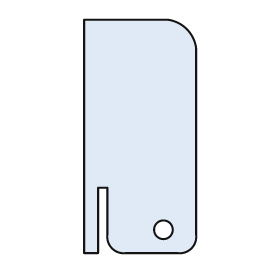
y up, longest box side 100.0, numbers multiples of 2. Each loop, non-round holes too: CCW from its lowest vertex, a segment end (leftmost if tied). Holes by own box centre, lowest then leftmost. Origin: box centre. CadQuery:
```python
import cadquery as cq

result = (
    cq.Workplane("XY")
    .moveTo(-24.0, -50.0)
    .lineTo(-18.0, -50.0)
    .lineTo(-18.0, -22.0)
    .lineTo(-14.0, -22.0)
    .lineTo(-14.0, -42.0)
    .threePointArc((-12.0, -48.0), (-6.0, -50.0))
    .lineTo(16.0, -50.0)
    .threePointArc((22.0, -48.0), (24.0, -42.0))
    .lineTo(24.0, 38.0)
    .threePointArc((20.0, 46.0), (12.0, 50.0))
    .lineTo(-24.0, 50.0)
    .close()
    .moveTo(10.0, -40.0)
    .circle(4.0)
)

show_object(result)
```